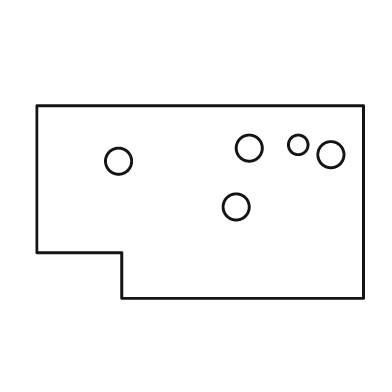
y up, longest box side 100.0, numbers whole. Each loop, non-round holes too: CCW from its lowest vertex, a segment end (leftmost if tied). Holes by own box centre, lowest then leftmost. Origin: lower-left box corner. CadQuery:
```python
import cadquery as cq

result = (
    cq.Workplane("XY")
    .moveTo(26.0, 0.0)
    .lineTo(100.0, 0.0)
    .lineTo(100.0, 59.0)
    .lineTo(0.0, 59.0)
    .lineTo(0.0, 14.0)
    .lineTo(26.0, 14.0)
    .close()
    .moveTo(61.0, 28.0)
    .circle(4.0)
    .moveTo(25.0, 42.0)
    .circle(4.0)
    .moveTo(90.0, 44.0)
    .circle(4.0)
    .moveTo(65.0, 46.0)
    .circle(4.0)
    .moveTo(80.0, 47.0)
    .circle(3.0)
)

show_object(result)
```